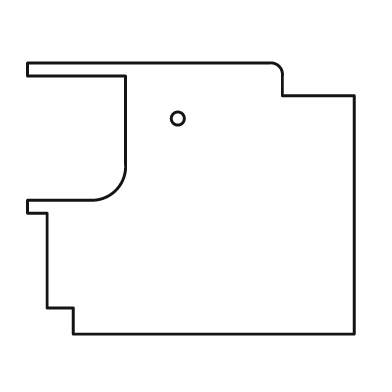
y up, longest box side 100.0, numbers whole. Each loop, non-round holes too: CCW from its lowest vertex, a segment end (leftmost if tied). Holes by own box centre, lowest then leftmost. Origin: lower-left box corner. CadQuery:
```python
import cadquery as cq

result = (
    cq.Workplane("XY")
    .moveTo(14.0, 0.0)
    .lineTo(100.0, 0.0)
    .lineTo(100.0, 73.0)
    .lineTo(78.0, 73.0)
    .lineTo(78.0, 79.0)
    .threePointArc((77.0, 82.0), (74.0, 83.0))
    .lineTo(0.0, 83.0)
    .lineTo(0.0, 79.0)
    .lineTo(30.0, 79.0)
    .lineTo(30.0, 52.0)
    .threePointArc((27.0, 44.0), (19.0, 41.0))
    .lineTo(0.0, 41.0)
    .lineTo(0.0, 37.0)
    .lineTo(6.0, 37.0)
    .lineTo(6.0, 8.0)
    .lineTo(14.0, 8.0)
    .close()
    .moveTo(46.0, 66.0)
    .circle(2.0)
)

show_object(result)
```